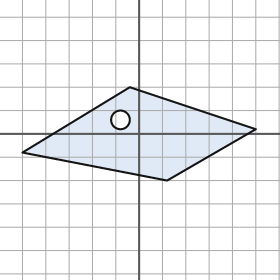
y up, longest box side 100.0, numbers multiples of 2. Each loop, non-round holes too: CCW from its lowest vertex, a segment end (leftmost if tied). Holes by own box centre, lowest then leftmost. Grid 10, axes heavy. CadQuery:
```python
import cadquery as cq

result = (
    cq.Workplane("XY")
    .moveTo(12.0, -20.0)
    .lineTo(50.0, 2.0)
    .lineTo(-4.0, 20.0)
    .lineTo(-50.0, -8.0)
    .close()
    .moveTo(-8.0, 6.0)
    .circle(4.0)
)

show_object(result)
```